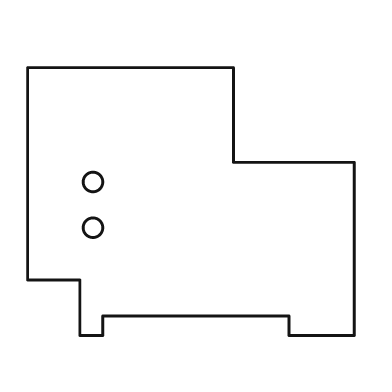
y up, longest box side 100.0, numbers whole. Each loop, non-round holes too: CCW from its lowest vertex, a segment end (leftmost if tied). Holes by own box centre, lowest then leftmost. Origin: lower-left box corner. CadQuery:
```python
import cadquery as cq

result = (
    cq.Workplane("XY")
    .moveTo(16.0, 0.0)
    .lineTo(23.0, 0.0)
    .lineTo(23.0, 6.0)
    .lineTo(80.0, 6.0)
    .lineTo(80.0, 0.0)
    .lineTo(100.0, 0.0)
    .lineTo(100.0, 53.0)
    .lineTo(63.0, 53.0)
    .lineTo(63.0, 82.0)
    .lineTo(0.0, 82.0)
    .lineTo(0.0, 17.0)
    .lineTo(16.0, 17.0)
    .close()
    .moveTo(20.0, 33.0)
    .circle(3.0)
    .moveTo(20.0, 47.0)
    .circle(3.0)
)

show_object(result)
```